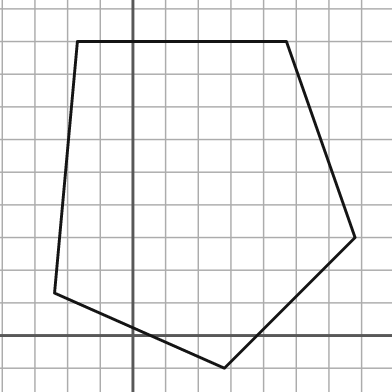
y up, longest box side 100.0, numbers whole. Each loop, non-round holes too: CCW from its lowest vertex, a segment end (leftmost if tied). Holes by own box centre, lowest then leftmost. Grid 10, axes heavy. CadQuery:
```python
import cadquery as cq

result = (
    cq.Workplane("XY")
    .moveTo(28.0, -10.0)
    .lineTo(68.0, 30.0)
    .lineTo(47.0, 90.0)
    .lineTo(-17.0, 90.0)
    .lineTo(-24.0, 13.0)
    .close()
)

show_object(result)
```